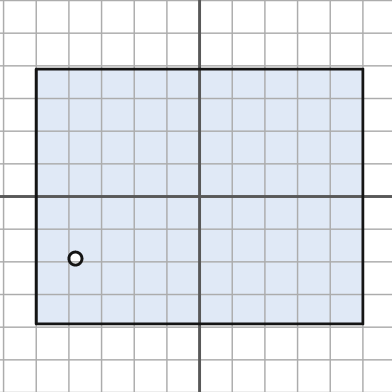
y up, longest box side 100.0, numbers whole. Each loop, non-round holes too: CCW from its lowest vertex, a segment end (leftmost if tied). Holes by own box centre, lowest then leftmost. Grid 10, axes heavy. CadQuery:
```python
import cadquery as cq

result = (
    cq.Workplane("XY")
    .moveTo(-50.0, -39.0)
    .lineTo(50.0, -39.0)
    .lineTo(50.0, 39.0)
    .lineTo(-50.0, 39.0)
    .close()
    .moveTo(-38.0, -19.0)
    .circle(2.0)
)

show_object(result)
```